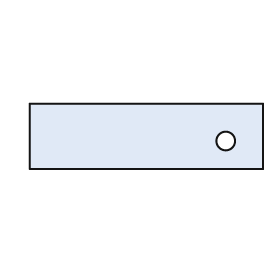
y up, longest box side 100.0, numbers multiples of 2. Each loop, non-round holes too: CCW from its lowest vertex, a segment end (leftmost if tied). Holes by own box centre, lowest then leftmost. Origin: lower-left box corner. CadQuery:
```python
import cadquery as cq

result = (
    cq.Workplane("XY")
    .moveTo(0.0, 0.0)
    .lineTo(100.0, 0.0)
    .lineTo(100.0, 28.0)
    .lineTo(0.0, 28.0)
    .close()
    .moveTo(84.0, 12.0)
    .circle(4.0)
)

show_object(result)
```